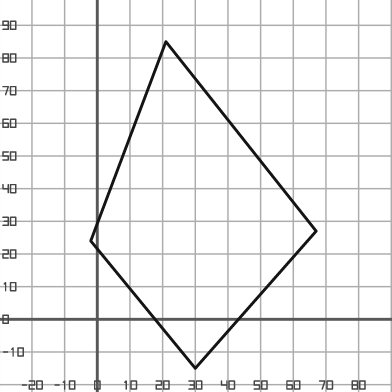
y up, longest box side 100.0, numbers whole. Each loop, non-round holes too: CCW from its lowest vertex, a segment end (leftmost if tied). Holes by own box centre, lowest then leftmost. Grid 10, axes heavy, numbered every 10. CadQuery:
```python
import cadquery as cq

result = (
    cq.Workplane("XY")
    .moveTo(30.0, -15.0)
    .lineTo(67.0, 27.0)
    .lineTo(21.0, 85.0)
    .lineTo(-2.0, 24.0)
    .close()
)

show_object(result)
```